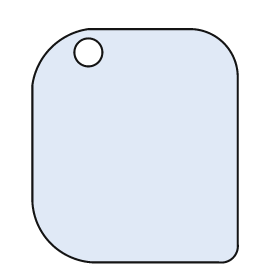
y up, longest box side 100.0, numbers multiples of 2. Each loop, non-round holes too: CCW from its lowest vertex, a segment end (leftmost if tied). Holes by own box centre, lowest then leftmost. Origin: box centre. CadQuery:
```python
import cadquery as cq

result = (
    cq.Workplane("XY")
    .moveTo(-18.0, -50.0)
    .lineTo(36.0, -50.0)
    .threePointArc((42.0, -48.0), (44.0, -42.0))
    .lineTo(44.0, 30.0)
    .threePointArc((38.0, 44.0), (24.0, 50.0))
    .lineTo(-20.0, 50.0)
    .threePointArc((-36.0, 42.0), (-44.0, 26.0))
    .lineTo(-44.0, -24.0)
    .threePointArc((-36.0, -42.0), (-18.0, -50.0))
    .close()
    .moveTo(-20.0, 40.0)
    .circle(6.0)
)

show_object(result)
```